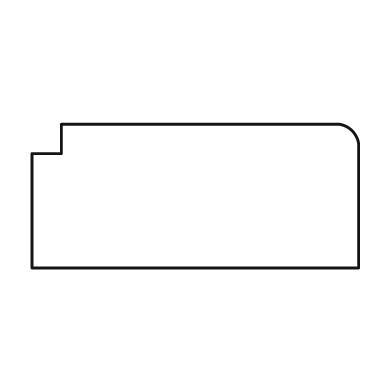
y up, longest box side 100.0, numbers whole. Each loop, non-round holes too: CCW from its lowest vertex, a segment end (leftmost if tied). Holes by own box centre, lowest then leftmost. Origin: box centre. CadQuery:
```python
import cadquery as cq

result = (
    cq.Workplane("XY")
    .moveTo(-50.0, -22.0)
    .lineTo(50.0, -22.0)
    .lineTo(50.0, 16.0)
    .threePointArc((48.0, 20.0), (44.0, 22.0))
    .lineTo(-41.0, 22.0)
    .lineTo(-41.0, 13.0)
    .lineTo(-50.0, 13.0)
    .close()
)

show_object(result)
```